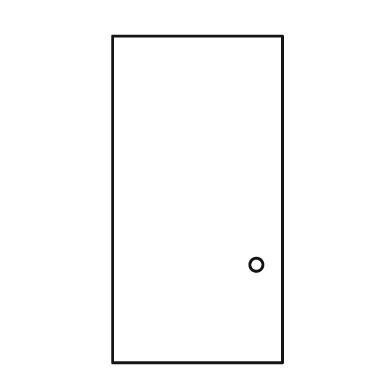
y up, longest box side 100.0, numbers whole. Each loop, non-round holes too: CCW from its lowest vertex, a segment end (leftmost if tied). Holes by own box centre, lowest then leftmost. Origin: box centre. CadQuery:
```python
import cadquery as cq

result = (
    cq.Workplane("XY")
    .moveTo(-26.0, -50.0)
    .lineTo(26.0, -50.0)
    .lineTo(26.0, 50.0)
    .lineTo(-26.0, 50.0)
    .close()
    .moveTo(18.0, -20.0)
    .circle(2.0)
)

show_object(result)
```